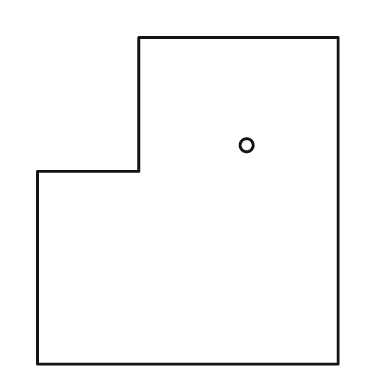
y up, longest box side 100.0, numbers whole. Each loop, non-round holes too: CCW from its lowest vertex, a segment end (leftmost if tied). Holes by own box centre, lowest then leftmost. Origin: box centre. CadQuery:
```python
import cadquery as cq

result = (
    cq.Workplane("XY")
    .moveTo(-46.0, -50.0)
    .lineTo(46.0, -50.0)
    .lineTo(46.0, 50.0)
    .lineTo(-15.0, 50.0)
    .lineTo(-15.0, 9.0)
    .lineTo(-46.0, 9.0)
    .close()
    .moveTo(18.0, 17.0)
    .circle(2.0)
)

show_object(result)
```